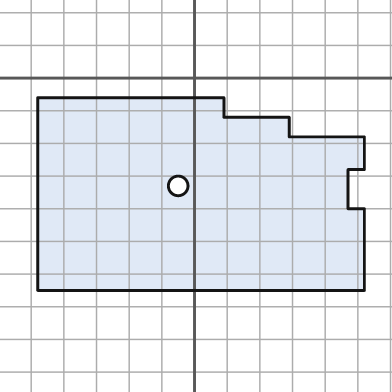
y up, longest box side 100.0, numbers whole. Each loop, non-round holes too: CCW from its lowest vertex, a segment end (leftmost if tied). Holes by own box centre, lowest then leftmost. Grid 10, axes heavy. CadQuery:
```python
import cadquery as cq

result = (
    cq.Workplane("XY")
    .moveTo(-48.0, -65.0)
    .lineTo(52.0, -65.0)
    .lineTo(52.0, -40.0)
    .lineTo(47.0, -40.0)
    .lineTo(47.0, -28.0)
    .lineTo(52.0, -28.0)
    .lineTo(52.0, -18.0)
    .lineTo(29.0, -18.0)
    .lineTo(29.0, -12.0)
    .lineTo(9.0, -12.0)
    .lineTo(9.0, -6.0)
    .lineTo(-48.0, -6.0)
    .close()
    .moveTo(-5.0, -33.0)
    .circle(3.0)
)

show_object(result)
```